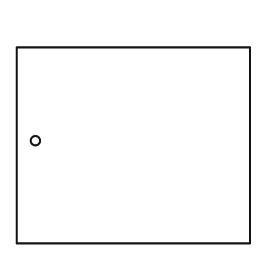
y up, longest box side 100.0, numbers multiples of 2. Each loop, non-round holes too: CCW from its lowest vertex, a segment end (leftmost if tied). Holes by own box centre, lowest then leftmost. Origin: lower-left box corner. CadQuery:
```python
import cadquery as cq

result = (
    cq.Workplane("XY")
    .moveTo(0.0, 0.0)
    .lineTo(100.0, 0.0)
    .lineTo(100.0, 84.0)
    .lineTo(0.0, 84.0)
    .close()
    .moveTo(8.0, 44.0)
    .circle(2.0)
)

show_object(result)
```